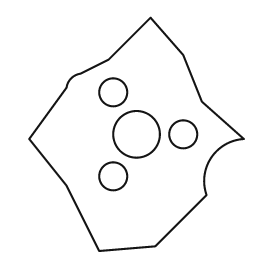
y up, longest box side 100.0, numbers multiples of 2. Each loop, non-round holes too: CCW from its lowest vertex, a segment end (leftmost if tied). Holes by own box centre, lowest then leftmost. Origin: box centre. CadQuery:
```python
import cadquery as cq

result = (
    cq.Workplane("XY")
    .moveTo(-16.0, -50.0)
    .lineTo(8.0, -48.0)
    .lineTo(30.0, -26.0)
    .threePointArc((32.0, -10.0), (46.0, -2.0))
    .lineTo(28.0, 14.0)
    .lineTo(20.0, 34.0)
    .lineTo(6.0, 50.0)
    .lineTo(-12.0, 32.0)
    .lineTo(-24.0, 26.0)
    .threePointArc((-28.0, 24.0), (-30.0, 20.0))
    .lineTo(-46.0, -2.0)
    .lineTo(-30.0, -22.0)
    .close()
    .moveTo(-10.0, -18.0)
    .circle(6.0)
    .moveTo(0.0, 0.0)
    .circle(10.0)
    .moveTo(20.0, 0.0)
    .circle(6.0)
    .moveTo(-10.0, 18.0)
    .circle(6.0)
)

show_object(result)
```